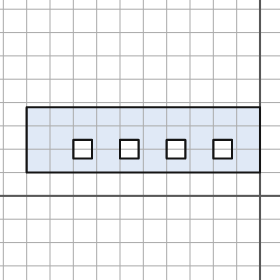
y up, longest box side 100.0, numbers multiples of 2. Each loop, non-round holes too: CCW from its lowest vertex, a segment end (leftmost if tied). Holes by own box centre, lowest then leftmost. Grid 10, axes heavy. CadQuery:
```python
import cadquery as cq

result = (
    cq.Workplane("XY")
    .moveTo(-100.0, 10.0)
    .lineTo(0.0, 10.0)
    .lineTo(0.0, 38.0)
    .lineTo(-100.0, 38.0)
    .close()
    .moveTo(-80.0, 16.0)
    .lineTo(-72.0, 16.0)
    .lineTo(-72.0, 24.0)
    .lineTo(-80.0, 24.0)
    .close()
    .moveTo(-60.0, 16.0)
    .lineTo(-52.0, 16.0)
    .lineTo(-52.0, 24.0)
    .lineTo(-60.0, 24.0)
    .close()
    .moveTo(-40.0, 16.0)
    .lineTo(-32.0, 16.0)
    .lineTo(-32.0, 24.0)
    .lineTo(-40.0, 24.0)
    .close()
    .moveTo(-20.0, 16.0)
    .lineTo(-12.0, 16.0)
    .lineTo(-12.0, 24.0)
    .lineTo(-20.0, 24.0)
    .close()
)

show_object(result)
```